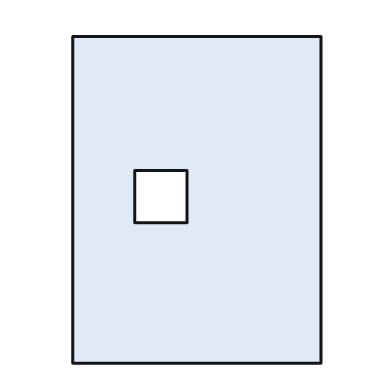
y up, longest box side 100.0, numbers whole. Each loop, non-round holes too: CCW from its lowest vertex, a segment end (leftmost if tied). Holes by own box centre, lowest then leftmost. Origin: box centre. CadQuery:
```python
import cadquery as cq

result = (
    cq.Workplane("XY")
    .moveTo(-38.0, -50.0)
    .lineTo(38.0, -50.0)
    .lineTo(38.0, 50.0)
    .lineTo(-38.0, 50.0)
    .close()
    .moveTo(-19.0, -7.0)
    .lineTo(-3.0, -7.0)
    .lineTo(-3.0, 9.0)
    .lineTo(-19.0, 9.0)
    .close()
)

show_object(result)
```